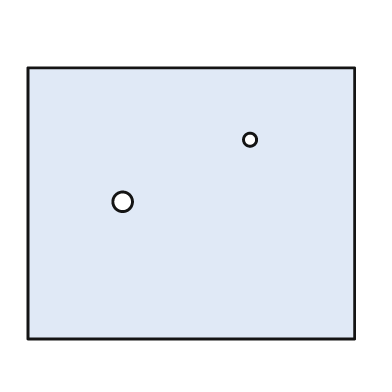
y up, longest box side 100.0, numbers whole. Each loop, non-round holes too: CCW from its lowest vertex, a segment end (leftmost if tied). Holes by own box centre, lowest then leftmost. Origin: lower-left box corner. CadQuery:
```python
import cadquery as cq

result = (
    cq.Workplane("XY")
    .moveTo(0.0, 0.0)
    .lineTo(100.0, 0.0)
    .lineTo(100.0, 83.0)
    .lineTo(0.0, 83.0)
    .close()
    .moveTo(29.0, 42.0)
    .circle(3.0)
    .moveTo(68.0, 61.0)
    .circle(2.0)
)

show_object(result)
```